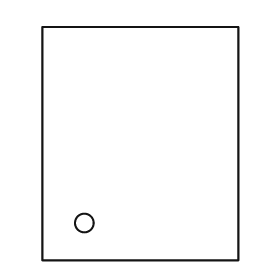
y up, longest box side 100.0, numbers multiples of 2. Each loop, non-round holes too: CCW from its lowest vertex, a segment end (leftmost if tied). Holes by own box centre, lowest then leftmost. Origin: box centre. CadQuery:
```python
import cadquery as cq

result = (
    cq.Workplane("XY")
    .moveTo(-42.0, -50.0)
    .lineTo(42.0, -50.0)
    .lineTo(42.0, 50.0)
    .lineTo(-42.0, 50.0)
    .close()
    .moveTo(-24.0, -34.0)
    .circle(4.0)
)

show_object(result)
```